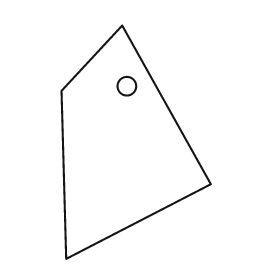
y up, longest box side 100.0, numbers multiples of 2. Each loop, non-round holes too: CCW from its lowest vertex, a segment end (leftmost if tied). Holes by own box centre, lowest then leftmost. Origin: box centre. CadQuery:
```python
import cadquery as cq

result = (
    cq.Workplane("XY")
    .moveTo(-30.0, -50.0)
    .lineTo(32.0, -18.0)
    .lineTo(-6.0, 50.0)
    .lineTo(-32.0, 22.0)
    .close()
    .moveTo(-4.0, 24.0)
    .circle(4.0)
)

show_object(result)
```